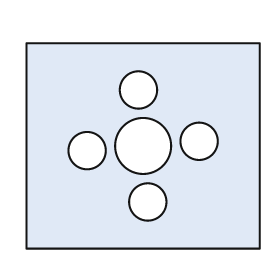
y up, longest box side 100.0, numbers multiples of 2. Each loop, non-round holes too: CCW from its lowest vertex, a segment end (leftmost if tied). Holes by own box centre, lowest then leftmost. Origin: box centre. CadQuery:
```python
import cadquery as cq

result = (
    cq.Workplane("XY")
    .moveTo(-50.0, -44.0)
    .lineTo(50.0, -44.0)
    .lineTo(50.0, 44.0)
    .lineTo(-50.0, 44.0)
    .close()
    .moveTo(2.0, -24.0)
    .circle(8.0)
    .moveTo(-24.0, -2.0)
    .circle(8.0)
    .moveTo(0.0, 0.0)
    .circle(12.0)
    .moveTo(24.0, 2.0)
    .circle(8.0)
    .moveTo(-2.0, 24.0)
    .circle(8.0)
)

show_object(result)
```